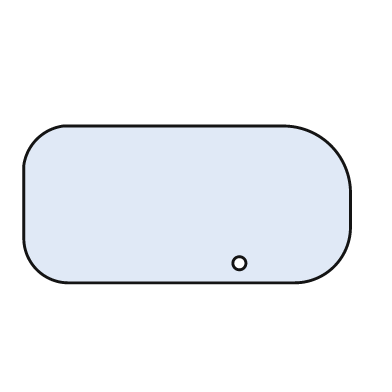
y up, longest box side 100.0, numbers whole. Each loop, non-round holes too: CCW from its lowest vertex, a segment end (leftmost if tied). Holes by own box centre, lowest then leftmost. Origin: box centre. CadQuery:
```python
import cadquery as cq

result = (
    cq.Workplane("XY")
    .moveTo(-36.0, -24.0)
    .lineTo(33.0, -24.0)
    .threePointArc((45.0, -19.0), (50.0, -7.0))
    .lineTo(50.0, 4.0)
    .threePointArc((44.0, 18.0), (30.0, 24.0))
    .lineTo(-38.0, 24.0)
    .threePointArc((-46.0, 20.0), (-50.0, 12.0))
    .lineTo(-50.0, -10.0)
    .threePointArc((-46.0, -20.0), (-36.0, -24.0))
    .close()
    .moveTo(16.0, -18.0)
    .circle(2.0)
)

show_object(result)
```